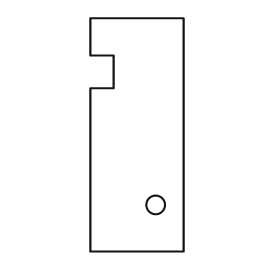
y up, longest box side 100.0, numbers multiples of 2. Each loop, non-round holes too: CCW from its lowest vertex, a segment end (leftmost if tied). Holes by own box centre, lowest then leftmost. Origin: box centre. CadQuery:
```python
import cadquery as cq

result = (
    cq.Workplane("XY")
    .moveTo(-20.0, -50.0)
    .lineTo(20.0, -50.0)
    .lineTo(20.0, 50.0)
    .lineTo(-20.0, 50.0)
    .lineTo(-20.0, 34.0)
    .lineTo(-10.0, 34.0)
    .lineTo(-10.0, 20.0)
    .lineTo(-20.0, 20.0)
    .close()
    .moveTo(8.0, -30.0)
    .circle(4.0)
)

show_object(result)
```